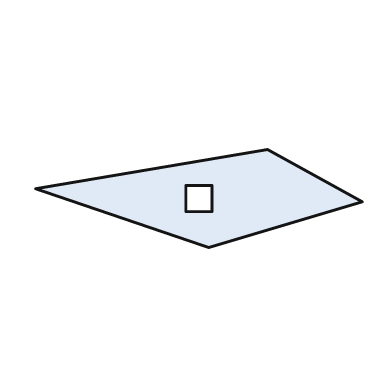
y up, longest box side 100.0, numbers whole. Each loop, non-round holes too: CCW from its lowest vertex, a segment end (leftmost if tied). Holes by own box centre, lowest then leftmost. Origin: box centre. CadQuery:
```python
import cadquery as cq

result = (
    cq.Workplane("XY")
    .moveTo(3.0, -15.0)
    .lineTo(50.0, -1.0)
    .lineTo(21.0, 15.0)
    .lineTo(-50.0, 3.0)
    .close()
    .moveTo(-4.0, -4.0)
    .lineTo(4.0, -4.0)
    .lineTo(4.0, 4.0)
    .lineTo(-4.0, 4.0)
    .close()
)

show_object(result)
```